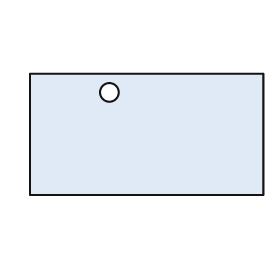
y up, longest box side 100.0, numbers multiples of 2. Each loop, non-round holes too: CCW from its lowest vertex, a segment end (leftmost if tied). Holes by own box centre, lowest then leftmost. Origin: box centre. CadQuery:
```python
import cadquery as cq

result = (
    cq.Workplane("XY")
    .moveTo(-50.0, -26.0)
    .lineTo(50.0, -26.0)
    .lineTo(50.0, 26.0)
    .lineTo(-50.0, 26.0)
    .close()
    .moveTo(-16.0, 18.0)
    .circle(4.0)
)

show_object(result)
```